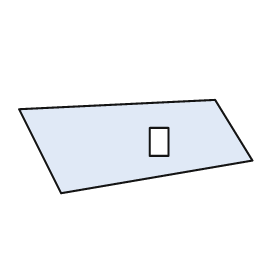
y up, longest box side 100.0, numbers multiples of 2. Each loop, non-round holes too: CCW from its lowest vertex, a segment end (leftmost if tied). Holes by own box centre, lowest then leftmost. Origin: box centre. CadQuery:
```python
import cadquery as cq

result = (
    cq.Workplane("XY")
    .moveTo(-32.0, -20.0)
    .lineTo(50.0, -6.0)
    .lineTo(34.0, 20.0)
    .lineTo(-50.0, 16.0)
    .close()
    .moveTo(6.0, -4.0)
    .lineTo(14.0, -4.0)
    .lineTo(14.0, 8.0)
    .lineTo(6.0, 8.0)
    .close()
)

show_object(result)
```